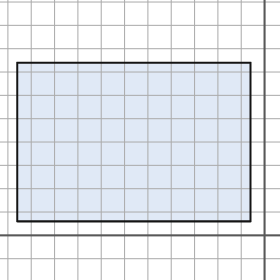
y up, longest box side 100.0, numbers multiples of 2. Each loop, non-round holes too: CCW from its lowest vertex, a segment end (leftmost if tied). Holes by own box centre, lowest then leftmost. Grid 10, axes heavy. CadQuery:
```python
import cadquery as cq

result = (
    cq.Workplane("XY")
    .moveTo(-106.0, 6.0)
    .lineTo(-6.0, 6.0)
    .lineTo(-6.0, 74.0)
    .lineTo(-106.0, 74.0)
    .close()
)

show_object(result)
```